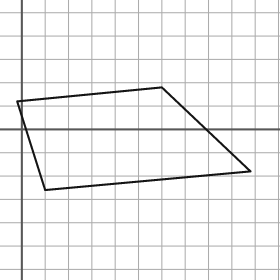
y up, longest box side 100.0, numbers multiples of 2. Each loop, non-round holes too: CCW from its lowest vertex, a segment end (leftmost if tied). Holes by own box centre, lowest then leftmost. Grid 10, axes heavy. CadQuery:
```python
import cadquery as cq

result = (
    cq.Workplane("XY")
    .moveTo(10.0, -26.0)
    .lineTo(98.0, -18.0)
    .lineTo(60.0, 18.0)
    .lineTo(-2.0, 12.0)
    .close()
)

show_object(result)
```